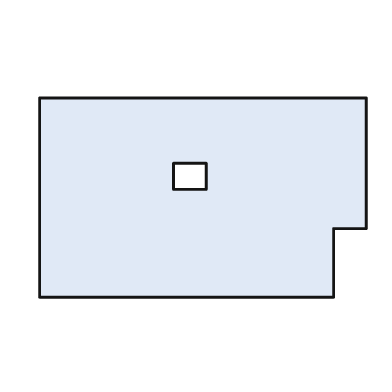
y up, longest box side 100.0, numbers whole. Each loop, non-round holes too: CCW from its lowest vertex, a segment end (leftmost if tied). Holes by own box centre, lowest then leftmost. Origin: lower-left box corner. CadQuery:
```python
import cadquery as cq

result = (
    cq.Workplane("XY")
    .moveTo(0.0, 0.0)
    .lineTo(90.0, 0.0)
    .lineTo(90.0, 21.0)
    .lineTo(100.0, 21.0)
    .lineTo(100.0, 61.0)
    .lineTo(0.0, 61.0)
    .close()
    .moveTo(41.0, 33.0)
    .lineTo(51.0, 33.0)
    .lineTo(51.0, 41.0)
    .lineTo(41.0, 41.0)
    .close()
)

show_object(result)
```